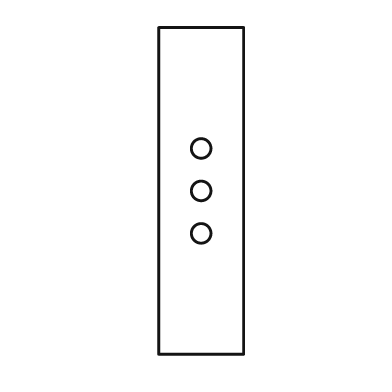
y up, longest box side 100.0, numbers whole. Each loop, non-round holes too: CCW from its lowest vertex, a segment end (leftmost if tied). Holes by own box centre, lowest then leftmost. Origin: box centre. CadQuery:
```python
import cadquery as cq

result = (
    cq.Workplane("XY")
    .moveTo(-13.0, -50.0)
    .lineTo(13.0, -50.0)
    .lineTo(13.0, 50.0)
    .lineTo(-13.0, 50.0)
    .close()
    .moveTo(0.0, -13.0)
    .circle(3.0)
    .moveTo(0.0, 0.0)
    .circle(3.0)
    .moveTo(0.0, 13.0)
    .circle(3.0)
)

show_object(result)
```